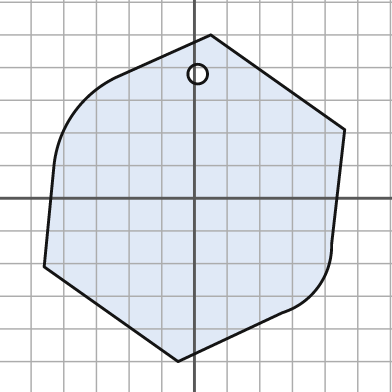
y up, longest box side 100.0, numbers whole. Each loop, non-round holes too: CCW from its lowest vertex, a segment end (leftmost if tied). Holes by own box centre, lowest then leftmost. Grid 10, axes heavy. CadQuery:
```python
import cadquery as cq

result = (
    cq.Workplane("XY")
    .moveTo(-5.0, -50.0)
    .lineTo(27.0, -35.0)
    .threePointArc((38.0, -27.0), (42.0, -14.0))
    .lineTo(46.0, 21.0)
    .lineTo(5.0, 50.0)
    .lineTo(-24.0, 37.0)
    .threePointArc((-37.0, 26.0), (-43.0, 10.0))
    .lineTo(-46.0, -21.0)
    .close()
    .moveTo(1.0, 38.0)
    .circle(3.0)
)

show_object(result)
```